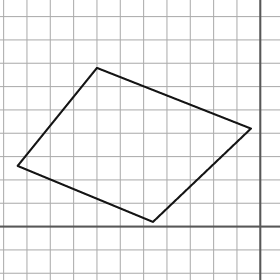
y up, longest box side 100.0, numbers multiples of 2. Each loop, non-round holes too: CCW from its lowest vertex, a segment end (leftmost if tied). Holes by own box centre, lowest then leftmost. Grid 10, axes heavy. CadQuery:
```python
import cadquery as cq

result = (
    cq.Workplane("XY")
    .moveTo(-46.0, 2.0)
    .lineTo(-4.0, 42.0)
    .lineTo(-70.0, 68.0)
    .lineTo(-104.0, 26.0)
    .close()
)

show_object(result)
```